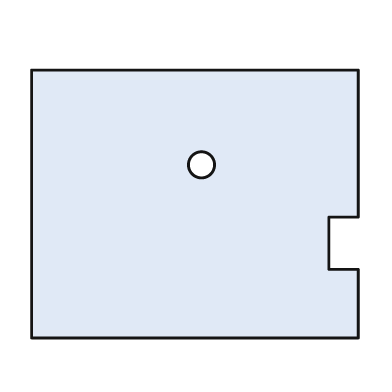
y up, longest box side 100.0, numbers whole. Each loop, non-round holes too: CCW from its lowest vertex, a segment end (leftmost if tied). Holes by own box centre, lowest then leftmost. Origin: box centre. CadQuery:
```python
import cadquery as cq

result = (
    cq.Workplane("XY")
    .moveTo(-50.0, -41.0)
    .lineTo(50.0, -41.0)
    .lineTo(50.0, -20.0)
    .lineTo(41.0, -20.0)
    .lineTo(41.0, -4.0)
    .lineTo(50.0, -4.0)
    .lineTo(50.0, 41.0)
    .lineTo(-50.0, 41.0)
    .close()
    .moveTo(2.0, 12.0)
    .circle(4.0)
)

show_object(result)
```